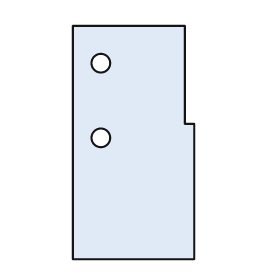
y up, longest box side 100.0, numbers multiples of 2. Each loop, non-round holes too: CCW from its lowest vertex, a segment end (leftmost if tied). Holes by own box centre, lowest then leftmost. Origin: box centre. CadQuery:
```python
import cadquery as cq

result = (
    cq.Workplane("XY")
    .moveTo(-26.0, -50.0)
    .lineTo(26.0, -50.0)
    .lineTo(26.0, 8.0)
    .lineTo(22.0, 8.0)
    .lineTo(22.0, 50.0)
    .lineTo(-26.0, 50.0)
    .close()
    .moveTo(-14.0, 2.0)
    .circle(4.0)
    .moveTo(-14.0, 34.0)
    .circle(4.0)
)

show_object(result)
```